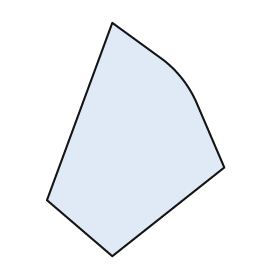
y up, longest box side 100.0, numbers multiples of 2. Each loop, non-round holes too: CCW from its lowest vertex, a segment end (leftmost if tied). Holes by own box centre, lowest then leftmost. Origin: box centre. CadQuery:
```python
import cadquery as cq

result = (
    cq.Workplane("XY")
    .moveTo(-10.0, -50.0)
    .lineTo(38.0, -12.0)
    .lineTo(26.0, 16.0)
    .threePointArc((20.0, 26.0), (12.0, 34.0))
    .lineTo(-10.0, 50.0)
    .lineTo(-38.0, -26.0)
    .close()
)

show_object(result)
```